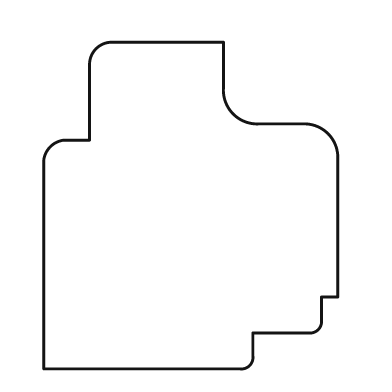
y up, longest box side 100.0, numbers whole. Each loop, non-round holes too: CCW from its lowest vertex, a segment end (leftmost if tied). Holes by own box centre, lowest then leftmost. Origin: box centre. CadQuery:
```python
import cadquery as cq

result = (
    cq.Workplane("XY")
    .moveTo(-45.0, -50.0)
    .lineTo(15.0, -50.0)
    .threePointArc((18.0, -49.0), (19.0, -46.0))
    .lineTo(19.0, -39.0)
    .lineTo(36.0, -39.0)
    .threePointArc((39.0, -38.0), (40.0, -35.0))
    .lineTo(40.0, -28.0)
    .lineTo(45.0, -28.0)
    .lineTo(45.0, 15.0)
    .threePointArc((42.0, 22.0), (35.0, 25.0))
    .lineTo(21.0, 25.0)
    .threePointArc((13.0, 28.0), (10.0, 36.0))
    .lineTo(10.0, 50.0)
    .lineTo(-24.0, 50.0)
    .threePointArc((-29.0, 48.0), (-31.0, 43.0))
    .lineTo(-31.0, 20.0)
    .lineTo(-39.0, 20.0)
    .threePointArc((-43.0, 18.0), (-45.0, 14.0))
    .close()
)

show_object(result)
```